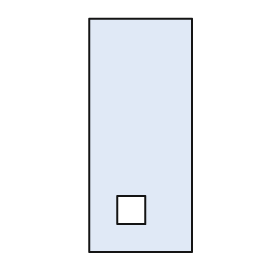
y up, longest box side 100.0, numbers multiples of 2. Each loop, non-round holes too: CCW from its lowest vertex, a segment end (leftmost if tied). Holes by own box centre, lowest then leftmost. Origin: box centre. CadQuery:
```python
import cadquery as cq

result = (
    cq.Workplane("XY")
    .moveTo(-22.0, -50.0)
    .lineTo(22.0, -50.0)
    .lineTo(22.0, 50.0)
    .lineTo(-22.0, 50.0)
    .close()
    .moveTo(-10.0, -38.0)
    .lineTo(2.0, -38.0)
    .lineTo(2.0, -26.0)
    .lineTo(-10.0, -26.0)
    .close()
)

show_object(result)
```